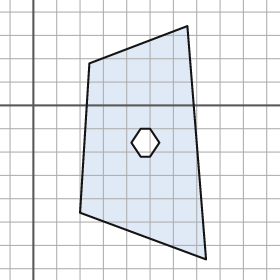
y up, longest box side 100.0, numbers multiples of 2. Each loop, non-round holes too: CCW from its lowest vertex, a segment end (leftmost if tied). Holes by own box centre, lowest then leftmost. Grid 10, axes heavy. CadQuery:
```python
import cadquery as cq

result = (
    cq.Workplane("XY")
    .moveTo(74.0, -66.0)
    .lineTo(66.0, 34.0)
    .lineTo(24.0, 18.0)
    .lineTo(20.0, -46.0)
    .close()
    .moveTo(46.0, -22.0)
    .lineTo(50.0, -22.0)
    .lineTo(54.0, -16.0)
    .lineTo(50.0, -10.0)
    .lineTo(46.0, -10.0)
    .lineTo(42.0, -16.0)
    .close()
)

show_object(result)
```